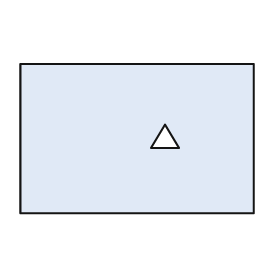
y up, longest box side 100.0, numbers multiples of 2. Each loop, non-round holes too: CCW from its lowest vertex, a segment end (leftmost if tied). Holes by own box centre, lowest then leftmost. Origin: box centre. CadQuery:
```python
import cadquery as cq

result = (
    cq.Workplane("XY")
    .moveTo(-50.0, -32.0)
    .lineTo(50.0, -32.0)
    .lineTo(50.0, 32.0)
    .lineTo(-50.0, 32.0)
    .close()
    .moveTo(6.0, -4.0)
    .lineTo(18.0, -4.0)
    .lineTo(12.0, 6.0)
    .close()
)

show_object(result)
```